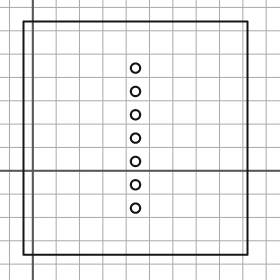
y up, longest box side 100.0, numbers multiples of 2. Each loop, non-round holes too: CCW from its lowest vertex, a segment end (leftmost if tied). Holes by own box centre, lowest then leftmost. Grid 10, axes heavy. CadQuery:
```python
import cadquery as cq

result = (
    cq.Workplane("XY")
    .moveTo(-4.0, -36.0)
    .lineTo(92.0, -36.0)
    .lineTo(92.0, 64.0)
    .lineTo(-4.0, 64.0)
    .close()
    .moveTo(44.0, -16.0)
    .circle(2.0)
    .moveTo(44.0, -6.0)
    .circle(2.0)
    .moveTo(44.0, 4.0)
    .circle(2.0)
    .moveTo(44.0, 14.0)
    .circle(2.0)
    .moveTo(44.0, 24.0)
    .circle(2.0)
    .moveTo(44.0, 34.0)
    .circle(2.0)
    .moveTo(44.0, 44.0)
    .circle(2.0)
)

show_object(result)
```